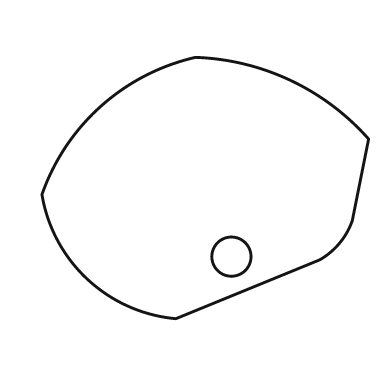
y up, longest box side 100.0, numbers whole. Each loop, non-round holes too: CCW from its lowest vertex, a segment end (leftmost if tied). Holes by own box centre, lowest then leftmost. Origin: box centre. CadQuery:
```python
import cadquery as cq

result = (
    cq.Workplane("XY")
    .moveTo(-9.0, -40.0)
    .lineTo(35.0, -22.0)
    .threePointArc((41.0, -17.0), (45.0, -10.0))
    .lineTo(50.0, 15.0)
    .threePointArc((26.0, 33.0), (-3.0, 40.0))
    .threePointArc((-32.0, 25.0), (-50.0, -2.0))
    .threePointArc((-36.0, -28.0), (-9.0, -40.0))
    .close()
    .moveTo(8.0, -21.0)
    .circle(6.0)
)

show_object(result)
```